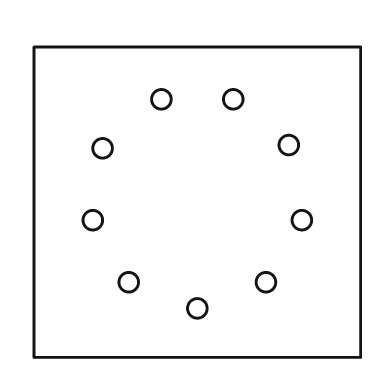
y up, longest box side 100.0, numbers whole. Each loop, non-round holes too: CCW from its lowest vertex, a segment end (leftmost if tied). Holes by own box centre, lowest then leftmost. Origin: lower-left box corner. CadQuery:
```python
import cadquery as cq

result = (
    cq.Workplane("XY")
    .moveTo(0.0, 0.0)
    .lineTo(100.0, 0.0)
    .lineTo(100.0, 95.0)
    .lineTo(0.0, 95.0)
    .close()
    .moveTo(50.0, 15.0)
    .circle(3.0)
    .moveTo(29.0, 23.0)
    .circle(3.0)
    .moveTo(71.0, 23.0)
    .circle(3.0)
    .moveTo(18.0, 42.0)
    .circle(3.0)
    .moveTo(82.0, 42.0)
    .circle(3.0)
    .moveTo(21.0, 64.0)
    .circle(3.0)
    .moveTo(78.0, 65.0)
    .circle(3.0)
    .moveTo(39.0, 79.0)
    .circle(3.0)
    .moveTo(61.0, 79.0)
    .circle(3.0)
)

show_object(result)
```